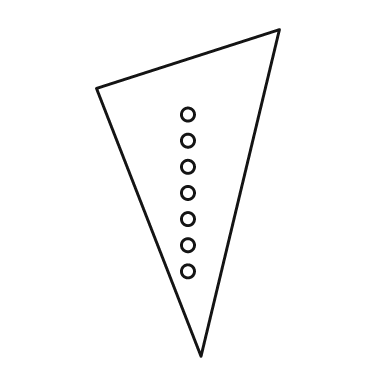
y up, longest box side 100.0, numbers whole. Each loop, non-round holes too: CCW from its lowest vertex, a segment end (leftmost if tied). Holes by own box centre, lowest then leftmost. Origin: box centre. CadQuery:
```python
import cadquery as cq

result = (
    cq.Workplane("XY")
    .moveTo(4.0, -50.0)
    .lineTo(28.0, 50.0)
    .lineTo(-28.0, 32.0)
    .close()
    .moveTo(0.0, -24.0)
    .circle(2.0)
    .moveTo(0.0, -16.0)
    .circle(2.0)
    .moveTo(0.0, -8.0)
    .circle(2.0)
    .moveTo(0.0, 0.0)
    .circle(2.0)
    .moveTo(0.0, 8.0)
    .circle(2.0)
    .moveTo(0.0, 16.0)
    .circle(2.0)
    .moveTo(0.0, 24.0)
    .circle(2.0)
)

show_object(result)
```